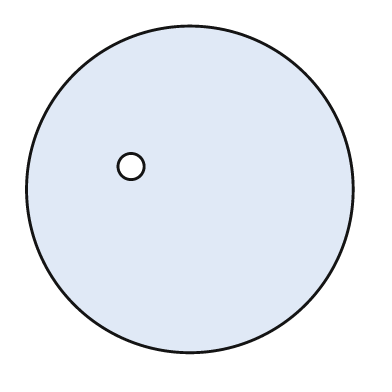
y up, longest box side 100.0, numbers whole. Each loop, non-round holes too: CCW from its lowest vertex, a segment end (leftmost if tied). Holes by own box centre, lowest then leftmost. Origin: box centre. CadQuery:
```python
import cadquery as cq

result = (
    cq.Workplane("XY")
    .moveTo(0.0, 0.0)
    .circle(50.0)
    .moveTo(-18.0, 7.0)
    .circle(4.0)
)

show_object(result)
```